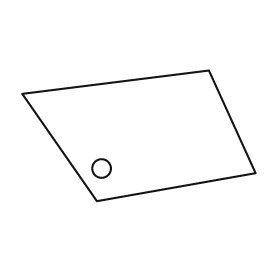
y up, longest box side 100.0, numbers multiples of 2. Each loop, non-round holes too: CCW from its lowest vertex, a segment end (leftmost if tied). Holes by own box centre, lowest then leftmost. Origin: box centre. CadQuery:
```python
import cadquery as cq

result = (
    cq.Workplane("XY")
    .moveTo(-18.0, -28.0)
    .lineTo(50.0, -16.0)
    .lineTo(30.0, 28.0)
    .lineTo(-50.0, 18.0)
    .close()
    .moveTo(-16.0, -14.0)
    .circle(4.0)
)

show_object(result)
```